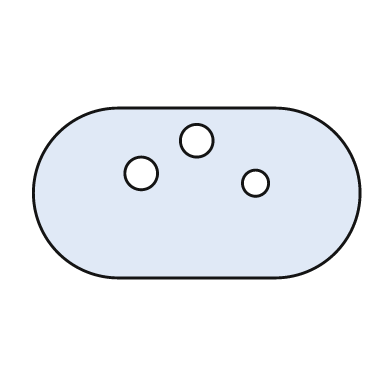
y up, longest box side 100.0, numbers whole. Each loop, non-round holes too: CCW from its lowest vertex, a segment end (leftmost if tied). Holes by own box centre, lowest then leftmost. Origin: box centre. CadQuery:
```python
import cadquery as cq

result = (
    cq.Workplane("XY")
    .moveTo(-24.0, -26.0)
    .lineTo(24.0, -26.0)
    .threePointArc((50.0, 0.0), (24.0, 26.0))
    .lineTo(-24.0, 26.0)
    .threePointArc((-50.0, 0.0), (-24.0, -26.0))
    .close()
    .moveTo(18.0, 3.0)
    .circle(4.0)
    .moveTo(-17.0, 6.0)
    .circle(5.0)
    .moveTo(0.0, 16.0)
    .circle(5.0)
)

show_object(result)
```